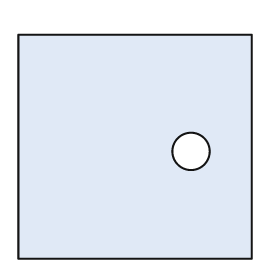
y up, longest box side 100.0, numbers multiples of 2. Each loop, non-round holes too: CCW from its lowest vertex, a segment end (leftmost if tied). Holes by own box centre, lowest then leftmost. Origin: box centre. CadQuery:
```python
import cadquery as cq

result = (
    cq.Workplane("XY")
    .moveTo(-50.0, -48.0)
    .lineTo(50.0, -48.0)
    .lineTo(50.0, 48.0)
    .lineTo(-50.0, 48.0)
    .close()
    .moveTo(24.0, -2.0)
    .circle(8.0)
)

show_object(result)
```